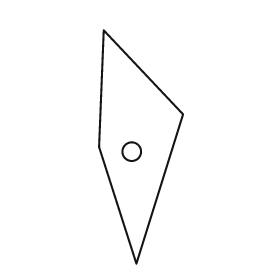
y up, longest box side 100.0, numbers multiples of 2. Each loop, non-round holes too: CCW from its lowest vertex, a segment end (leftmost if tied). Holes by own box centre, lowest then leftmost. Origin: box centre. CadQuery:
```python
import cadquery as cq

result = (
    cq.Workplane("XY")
    .moveTo(-2.0, -50.0)
    .lineTo(18.0, 14.0)
    .lineTo(-16.0, 50.0)
    .lineTo(-18.0, 0.0)
    .close()
    .moveTo(-4.0, -2.0)
    .circle(4.0)
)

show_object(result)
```